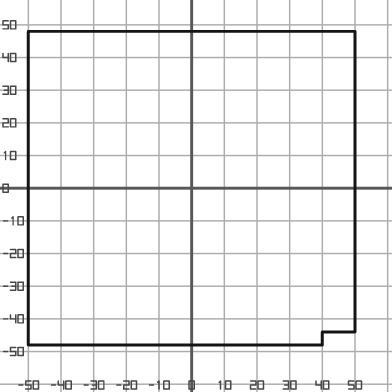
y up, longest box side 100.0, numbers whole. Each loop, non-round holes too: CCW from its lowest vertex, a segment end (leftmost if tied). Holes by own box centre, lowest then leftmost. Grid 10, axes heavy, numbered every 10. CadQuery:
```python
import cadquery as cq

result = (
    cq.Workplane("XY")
    .moveTo(-50.0, -48.0)
    .lineTo(40.0, -48.0)
    .lineTo(40.0, -44.0)
    .lineTo(50.0, -44.0)
    .lineTo(50.0, 48.0)
    .lineTo(-50.0, 48.0)
    .close()
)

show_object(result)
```